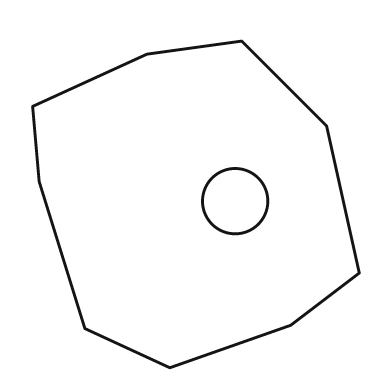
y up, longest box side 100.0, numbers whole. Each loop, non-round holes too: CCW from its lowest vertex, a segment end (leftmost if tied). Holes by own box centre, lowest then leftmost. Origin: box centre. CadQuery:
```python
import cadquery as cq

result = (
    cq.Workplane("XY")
    .moveTo(-8.0, -50.0)
    .lineTo(29.0, -37.0)
    .lineTo(50.0, -21.0)
    .lineTo(40.0, 24.0)
    .lineTo(14.0, 50.0)
    .lineTo(-15.0, 46.0)
    .lineTo(-50.0, 30.0)
    .lineTo(-48.0, 7.0)
    .lineTo(-34.0, -38.0)
    .close()
    .moveTo(12.0, 1.0)
    .circle(10.0)
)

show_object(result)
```